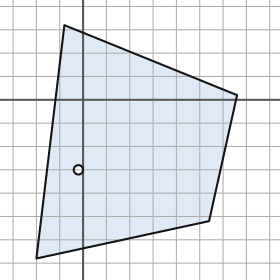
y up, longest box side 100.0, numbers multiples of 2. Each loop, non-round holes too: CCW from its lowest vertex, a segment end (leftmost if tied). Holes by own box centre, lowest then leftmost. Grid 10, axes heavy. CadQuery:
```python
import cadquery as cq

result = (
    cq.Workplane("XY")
    .moveTo(-20.0, -68.0)
    .lineTo(54.0, -52.0)
    .lineTo(66.0, 2.0)
    .lineTo(-8.0, 32.0)
    .close()
    .moveTo(-2.0, -30.0)
    .circle(2.0)
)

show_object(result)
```